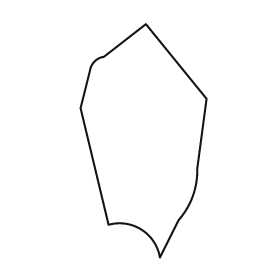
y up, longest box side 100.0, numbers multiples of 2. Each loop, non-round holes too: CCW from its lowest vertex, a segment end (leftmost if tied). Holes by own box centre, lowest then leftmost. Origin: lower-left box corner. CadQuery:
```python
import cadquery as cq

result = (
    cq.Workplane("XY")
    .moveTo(34.0, 0.0)
    .lineTo(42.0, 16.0)
    .threePointArc((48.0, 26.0), (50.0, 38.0))
    .lineTo(54.0, 68.0)
    .lineTo(28.0, 100.0)
    .lineTo(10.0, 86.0)
    .threePointArc((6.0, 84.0), (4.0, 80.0))
    .lineTo(0.0, 64.0)
    .lineTo(12.0, 14.0)
    .threePointArc((26.0, 12.0), (34.0, 0.0))
    .close()
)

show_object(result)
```